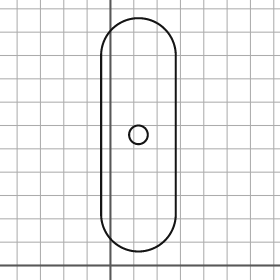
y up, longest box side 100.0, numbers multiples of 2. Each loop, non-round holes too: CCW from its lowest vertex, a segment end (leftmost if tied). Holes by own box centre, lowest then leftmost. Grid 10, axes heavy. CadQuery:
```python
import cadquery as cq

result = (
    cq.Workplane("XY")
    .moveTo(-4.0, 22.0)
    .threePointArc((12.0, 6.0), (28.0, 22.0))
    .lineTo(28.0, 90.0)
    .threePointArc((12.0, 106.0), (-4.0, 90.0))
    .close()
    .moveTo(12.0, 56.0)
    .circle(4.0)
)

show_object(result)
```